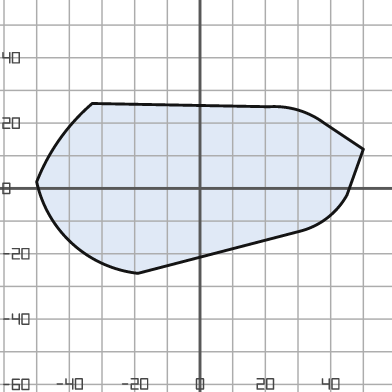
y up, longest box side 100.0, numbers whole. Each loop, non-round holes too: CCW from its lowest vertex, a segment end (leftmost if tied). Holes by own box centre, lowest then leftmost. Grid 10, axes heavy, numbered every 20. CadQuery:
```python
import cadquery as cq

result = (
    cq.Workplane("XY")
    .moveTo(-19.0, -26.0)
    .lineTo(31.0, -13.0)
    .threePointArc((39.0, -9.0), (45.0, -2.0))
    .lineTo(50.0, 12.0)
    .lineTo(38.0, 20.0)
    .threePointArc((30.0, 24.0), (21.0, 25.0))
    .lineTo(-33.0, 26.0)
    .threePointArc((-43.0, 15.0), (-50.0, 2.0))
    .threePointArc((-39.0, -17.0), (-19.0, -26.0))
    .close()
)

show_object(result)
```